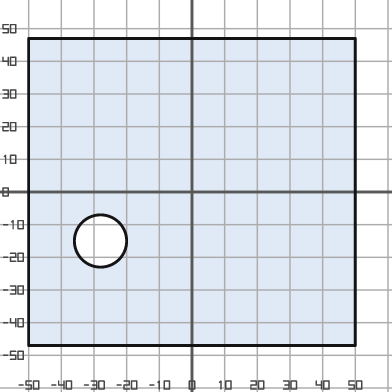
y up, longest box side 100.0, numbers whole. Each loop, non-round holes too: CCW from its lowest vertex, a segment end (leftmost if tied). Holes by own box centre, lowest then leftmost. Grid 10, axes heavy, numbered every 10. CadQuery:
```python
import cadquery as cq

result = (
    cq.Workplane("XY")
    .moveTo(-50.0, -47.0)
    .lineTo(50.0, -47.0)
    .lineTo(50.0, 47.0)
    .lineTo(-50.0, 47.0)
    .close()
    .moveTo(-28.0, -15.0)
    .circle(8.0)
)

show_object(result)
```